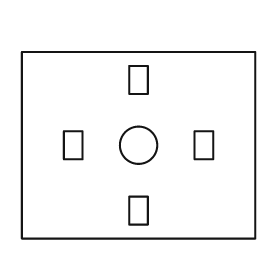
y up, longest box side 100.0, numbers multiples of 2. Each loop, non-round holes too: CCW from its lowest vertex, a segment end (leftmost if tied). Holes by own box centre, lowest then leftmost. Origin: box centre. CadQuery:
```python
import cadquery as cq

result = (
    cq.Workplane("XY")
    .moveTo(-50.0, -40.0)
    .lineTo(50.0, -40.0)
    .lineTo(50.0, 40.0)
    .lineTo(-50.0, 40.0)
    .close()
    .moveTo(-4.0, -34.0)
    .lineTo(4.0, -34.0)
    .lineTo(4.0, -22.0)
    .lineTo(-4.0, -22.0)
    .close()
    .moveTo(-32.0, -6.0)
    .lineTo(-24.0, -6.0)
    .lineTo(-24.0, 6.0)
    .lineTo(-32.0, 6.0)
    .close()
    .moveTo(0.0, 0.0)
    .circle(8.0)
    .moveTo(24.0, -6.0)
    .lineTo(32.0, -6.0)
    .lineTo(32.0, 6.0)
    .lineTo(24.0, 6.0)
    .close()
    .moveTo(-4.0, 22.0)
    .lineTo(4.0, 22.0)
    .lineTo(4.0, 34.0)
    .lineTo(-4.0, 34.0)
    .close()
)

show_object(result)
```